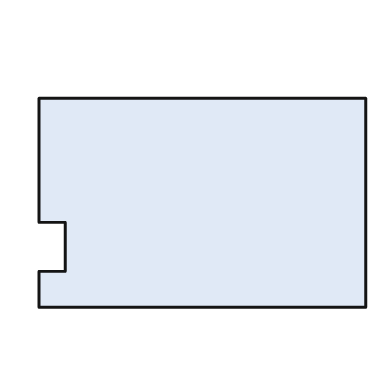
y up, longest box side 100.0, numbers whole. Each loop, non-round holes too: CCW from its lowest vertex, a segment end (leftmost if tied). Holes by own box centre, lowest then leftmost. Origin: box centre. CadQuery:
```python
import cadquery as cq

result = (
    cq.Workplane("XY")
    .moveTo(-50.0, -32.0)
    .lineTo(50.0, -32.0)
    .lineTo(50.0, 32.0)
    .lineTo(-50.0, 32.0)
    .lineTo(-50.0, -6.0)
    .lineTo(-42.0, -6.0)
    .lineTo(-42.0, -21.0)
    .lineTo(-50.0, -21.0)
    .close()
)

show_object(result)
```